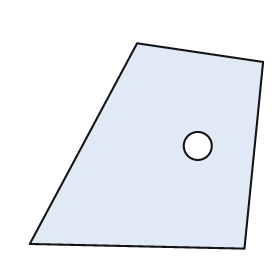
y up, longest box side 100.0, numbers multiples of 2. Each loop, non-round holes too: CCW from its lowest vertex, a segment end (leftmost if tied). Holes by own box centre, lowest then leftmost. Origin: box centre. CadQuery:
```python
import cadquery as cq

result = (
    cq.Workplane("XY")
    .moveTo(42.0, -44.0)
    .lineTo(50.0, 36.0)
    .lineTo(-4.0, 44.0)
    .lineTo(-50.0, -42.0)
    .close()
    .moveTo(22.0, 0.0)
    .circle(6.0)
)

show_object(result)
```